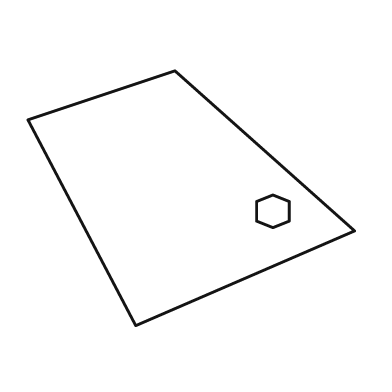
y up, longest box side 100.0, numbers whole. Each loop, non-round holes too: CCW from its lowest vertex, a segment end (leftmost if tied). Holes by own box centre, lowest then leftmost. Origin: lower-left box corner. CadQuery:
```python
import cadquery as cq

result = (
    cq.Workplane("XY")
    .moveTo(33.0, 0.0)
    .lineTo(100.0, 29.0)
    .lineTo(45.0, 78.0)
    .lineTo(0.0, 63.0)
    .close()
    .moveTo(75.0, 30.0)
    .lineTo(80.0, 32.0)
    .lineTo(80.0, 38.0)
    .lineTo(75.0, 40.0)
    .lineTo(70.0, 38.0)
    .lineTo(70.0, 32.0)
    .close()
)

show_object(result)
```